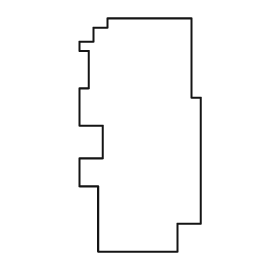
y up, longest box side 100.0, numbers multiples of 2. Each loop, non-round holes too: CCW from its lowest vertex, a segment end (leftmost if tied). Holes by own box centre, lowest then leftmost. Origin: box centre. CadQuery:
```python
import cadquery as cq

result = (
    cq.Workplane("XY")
    .moveTo(-18.0, -50.0)
    .lineTo(16.0, -50.0)
    .lineTo(16.0, -38.0)
    .lineTo(26.0, -38.0)
    .lineTo(26.0, 16.0)
    .lineTo(22.0, 16.0)
    .lineTo(22.0, 50.0)
    .lineTo(-14.0, 50.0)
    .lineTo(-14.0, 46.0)
    .lineTo(-20.0, 46.0)
    .lineTo(-20.0, 40.0)
    .lineTo(-26.0, 40.0)
    .lineTo(-26.0, 36.0)
    .lineTo(-22.0, 36.0)
    .lineTo(-22.0, 20.0)
    .lineTo(-26.0, 20.0)
    .lineTo(-26.0, 4.0)
    .lineTo(-16.0, 4.0)
    .lineTo(-16.0, -10.0)
    .lineTo(-26.0, -10.0)
    .lineTo(-26.0, -22.0)
    .lineTo(-18.0, -22.0)
    .close()
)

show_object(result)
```